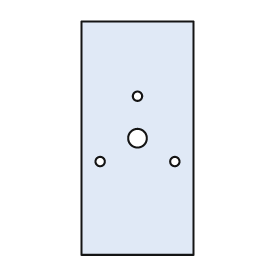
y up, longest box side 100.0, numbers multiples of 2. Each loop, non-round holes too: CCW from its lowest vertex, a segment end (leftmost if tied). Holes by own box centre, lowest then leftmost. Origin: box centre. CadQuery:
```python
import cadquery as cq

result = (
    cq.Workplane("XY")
    .moveTo(-24.0, -50.0)
    .lineTo(24.0, -50.0)
    .lineTo(24.0, 50.0)
    .lineTo(-24.0, 50.0)
    .close()
    .moveTo(-16.0, -10.0)
    .circle(2.0)
    .moveTo(16.0, -10.0)
    .circle(2.0)
    .moveTo(0.0, 0.0)
    .circle(4.0)
    .moveTo(0.0, 18.0)
    .circle(2.0)
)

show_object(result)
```